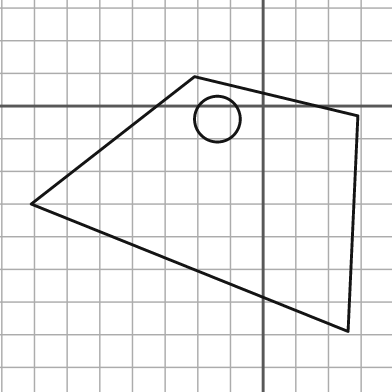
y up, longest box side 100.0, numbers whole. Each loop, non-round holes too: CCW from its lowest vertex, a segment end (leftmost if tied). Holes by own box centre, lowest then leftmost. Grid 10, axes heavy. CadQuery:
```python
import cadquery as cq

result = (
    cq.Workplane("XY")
    .moveTo(26.0, -69.0)
    .lineTo(29.0, -3.0)
    .lineTo(-21.0, 9.0)
    .lineTo(-71.0, -30.0)
    .close()
    .moveTo(-14.0, -4.0)
    .circle(7.0)
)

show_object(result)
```